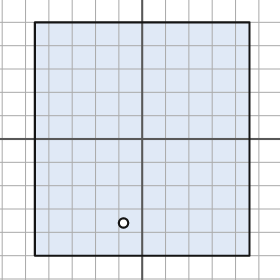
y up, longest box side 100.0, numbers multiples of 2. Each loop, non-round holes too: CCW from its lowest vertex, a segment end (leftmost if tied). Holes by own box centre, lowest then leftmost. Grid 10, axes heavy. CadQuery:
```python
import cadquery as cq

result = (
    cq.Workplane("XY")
    .moveTo(-46.0, -50.0)
    .lineTo(46.0, -50.0)
    .lineTo(46.0, 50.0)
    .lineTo(-46.0, 50.0)
    .close()
    .moveTo(-8.0, -36.0)
    .circle(2.0)
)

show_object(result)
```